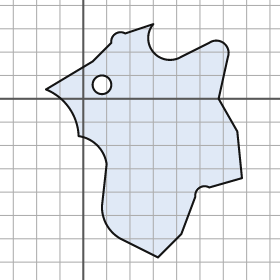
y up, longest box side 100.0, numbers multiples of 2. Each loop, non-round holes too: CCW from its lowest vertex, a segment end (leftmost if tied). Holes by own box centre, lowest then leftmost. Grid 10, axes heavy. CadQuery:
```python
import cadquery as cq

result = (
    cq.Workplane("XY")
    .moveTo(32.0, -68.0)
    .lineTo(42.0, -58.0)
    .lineTo(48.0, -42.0)
    .threePointArc((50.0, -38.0), (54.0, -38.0))
    .lineTo(68.0, -34.0)
    .lineTo(66.0, -14.0)
    .lineTo(58.0, 0.0)
    .lineTo(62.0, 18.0)
    .threePointArc((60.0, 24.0), (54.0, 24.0))
    .lineTo(42.0, 18.0)
    .threePointArc((30.0, 20.0), (30.0, 32.0))
    .lineTo(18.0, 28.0)
    .threePointArc((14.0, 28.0), (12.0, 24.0))
    .lineTo(4.0, 16.0)
    .lineTo(-16.0, 4.0)
    .threePointArc((-6.0, -4.0), (-2.0, -16.0))
    .threePointArc((6.0, -20.0), (10.0, -28.0))
    .lineTo(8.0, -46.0)
    .threePointArc((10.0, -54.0), (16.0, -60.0))
    .close()
    .moveTo(8.0, 6.0)
    .circle(4.0)
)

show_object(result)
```